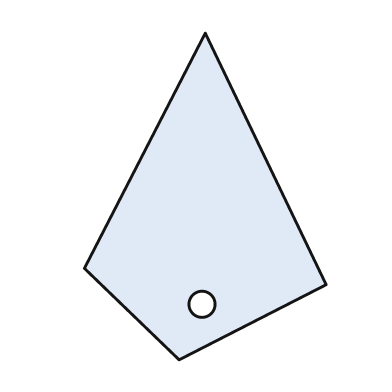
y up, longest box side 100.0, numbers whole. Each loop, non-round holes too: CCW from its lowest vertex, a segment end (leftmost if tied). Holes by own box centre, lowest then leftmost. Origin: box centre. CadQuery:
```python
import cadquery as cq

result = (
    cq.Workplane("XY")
    .moveTo(-8.0, -50.0)
    .lineTo(37.0, -27.0)
    .lineTo(0.0, 50.0)
    .lineTo(-37.0, -22.0)
    .close()
    .moveTo(-1.0, -33.0)
    .circle(4.0)
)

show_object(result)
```